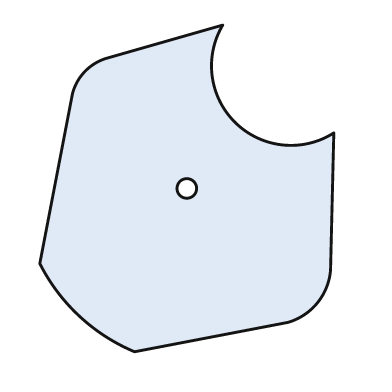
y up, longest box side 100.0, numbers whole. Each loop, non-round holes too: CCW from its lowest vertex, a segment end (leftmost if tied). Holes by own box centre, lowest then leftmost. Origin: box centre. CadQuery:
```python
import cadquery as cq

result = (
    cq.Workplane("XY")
    .moveTo(-16.0, -50.0)
    .lineTo(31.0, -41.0)
    .threePointArc((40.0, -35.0), (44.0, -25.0))
    .lineTo(45.0, 17.0)
    .threePointArc((15.0, 20.0), (11.0, 50.0))
    .lineTo(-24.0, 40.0)
    .threePointArc((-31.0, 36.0), (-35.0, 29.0))
    .lineTo(-45.0, -23.0)
    .threePointArc((-33.0, -39.0), (-16.0, -50.0))
    .close()
    .moveTo(0.0, 0.0)
    .circle(3.0)
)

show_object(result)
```